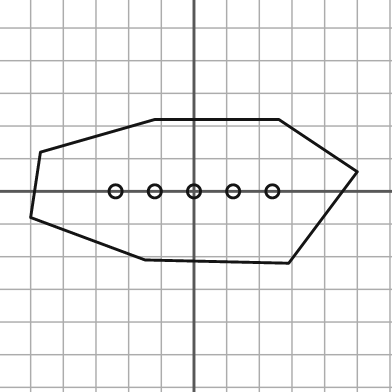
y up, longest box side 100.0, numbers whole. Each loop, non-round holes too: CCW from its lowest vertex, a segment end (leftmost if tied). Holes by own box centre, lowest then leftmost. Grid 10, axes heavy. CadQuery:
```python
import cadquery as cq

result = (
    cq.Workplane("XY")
    .moveTo(29.0, -22.0)
    .lineTo(50.0, 6.0)
    .lineTo(26.0, 22.0)
    .lineTo(-12.0, 22.0)
    .lineTo(-47.0, 12.0)
    .lineTo(-50.0, -8.0)
    .lineTo(-15.0, -21.0)
    .close()
    .moveTo(-24.0, 0.0)
    .circle(2.0)
    .moveTo(-12.0, 0.0)
    .circle(2.0)
    .moveTo(0.0, 0.0)
    .circle(2.0)
    .moveTo(12.0, 0.0)
    .circle(2.0)
    .moveTo(24.0, 0.0)
    .circle(2.0)
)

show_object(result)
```